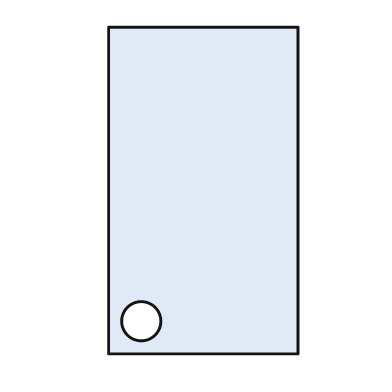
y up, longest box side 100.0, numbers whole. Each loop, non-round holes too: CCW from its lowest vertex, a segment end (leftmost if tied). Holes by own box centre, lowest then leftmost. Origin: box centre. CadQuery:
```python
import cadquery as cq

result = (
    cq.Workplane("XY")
    .moveTo(-29.0, -50.0)
    .lineTo(29.0, -50.0)
    .lineTo(29.0, 50.0)
    .lineTo(-29.0, 50.0)
    .close()
    .moveTo(-19.0, -40.0)
    .circle(6.0)
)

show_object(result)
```